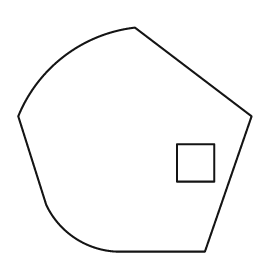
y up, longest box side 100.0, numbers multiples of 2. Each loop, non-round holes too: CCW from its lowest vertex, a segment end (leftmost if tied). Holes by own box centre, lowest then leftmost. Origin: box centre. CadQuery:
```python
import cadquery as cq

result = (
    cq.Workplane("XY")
    .moveTo(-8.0, -48.0)
    .lineTo(30.0, -48.0)
    .lineTo(50.0, 10.0)
    .lineTo(0.0, 48.0)
    .threePointArc((-30.0, 36.0), (-50.0, 10.0))
    .lineTo(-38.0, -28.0)
    .threePointArc((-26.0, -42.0), (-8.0, -48.0))
    .close()
    .moveTo(18.0, -18.0)
    .lineTo(34.0, -18.0)
    .lineTo(34.0, -2.0)
    .lineTo(18.0, -2.0)
    .close()
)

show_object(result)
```